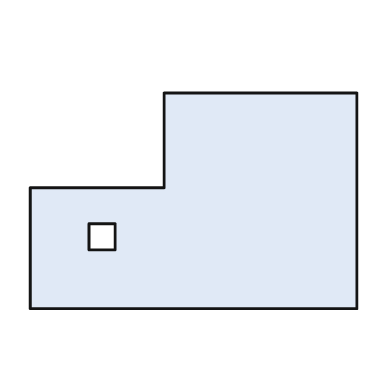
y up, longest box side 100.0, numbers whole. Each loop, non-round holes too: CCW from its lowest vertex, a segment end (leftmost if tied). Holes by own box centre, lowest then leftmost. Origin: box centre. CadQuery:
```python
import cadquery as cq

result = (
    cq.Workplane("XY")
    .moveTo(-50.0, -33.0)
    .lineTo(50.0, -33.0)
    .lineTo(50.0, 33.0)
    .lineTo(-9.0, 33.0)
    .lineTo(-9.0, 4.0)
    .lineTo(-50.0, 4.0)
    .close()
    .moveTo(-32.0, -15.0)
    .lineTo(-24.0, -15.0)
    .lineTo(-24.0, -7.0)
    .lineTo(-32.0, -7.0)
    .close()
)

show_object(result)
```